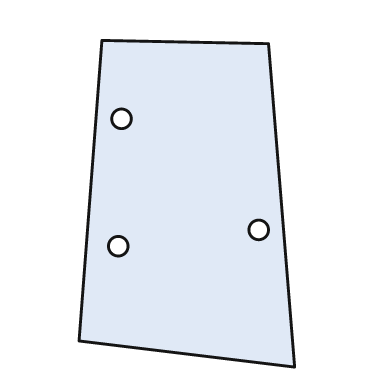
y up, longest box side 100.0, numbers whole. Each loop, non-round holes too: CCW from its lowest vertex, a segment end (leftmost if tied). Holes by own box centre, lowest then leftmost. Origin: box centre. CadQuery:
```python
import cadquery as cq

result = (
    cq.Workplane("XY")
    .moveTo(33.0, -50.0)
    .lineTo(25.0, 49.0)
    .lineTo(-26.0, 50.0)
    .lineTo(-33.0, -42.0)
    .close()
    .moveTo(-21.0, -13.0)
    .circle(3.0)
    .moveTo(22.0, -8.0)
    .circle(3.0)
    .moveTo(-20.0, 26.0)
    .circle(3.0)
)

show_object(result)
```